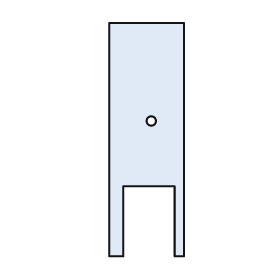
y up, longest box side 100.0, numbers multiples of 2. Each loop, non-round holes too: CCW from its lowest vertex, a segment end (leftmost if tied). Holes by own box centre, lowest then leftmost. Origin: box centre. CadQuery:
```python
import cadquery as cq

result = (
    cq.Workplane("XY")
    .moveTo(-16.0, -50.0)
    .lineTo(-10.0, -50.0)
    .lineTo(-10.0, -20.0)
    .lineTo(12.0, -20.0)
    .lineTo(12.0, -50.0)
    .lineTo(16.0, -50.0)
    .lineTo(16.0, 50.0)
    .lineTo(-16.0, 50.0)
    .close()
    .moveTo(2.0, 8.0)
    .circle(2.0)
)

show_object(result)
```